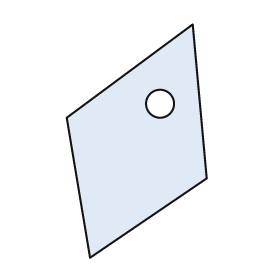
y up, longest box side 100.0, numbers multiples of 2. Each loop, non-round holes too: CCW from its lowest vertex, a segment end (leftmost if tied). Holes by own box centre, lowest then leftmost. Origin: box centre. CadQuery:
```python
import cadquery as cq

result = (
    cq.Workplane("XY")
    .moveTo(-20.0, -50.0)
    .lineTo(30.0, -16.0)
    .lineTo(24.0, 50.0)
    .lineTo(-30.0, 10.0)
    .close()
    .moveTo(10.0, 16.0)
    .circle(6.0)
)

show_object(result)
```